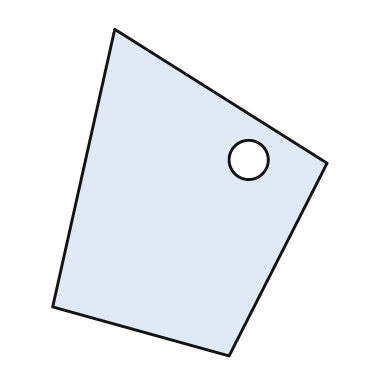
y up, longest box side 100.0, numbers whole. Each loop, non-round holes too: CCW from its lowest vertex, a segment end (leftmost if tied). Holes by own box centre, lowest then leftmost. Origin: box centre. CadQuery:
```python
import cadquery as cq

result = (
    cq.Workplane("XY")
    .moveTo(12.0, -50.0)
    .lineTo(42.0, 9.0)
    .lineTo(-23.0, 50.0)
    .lineTo(-42.0, -35.0)
    .close()
    .moveTo(18.0, 10.0)
    .circle(6.0)
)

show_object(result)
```